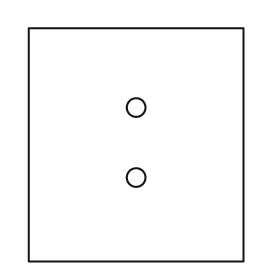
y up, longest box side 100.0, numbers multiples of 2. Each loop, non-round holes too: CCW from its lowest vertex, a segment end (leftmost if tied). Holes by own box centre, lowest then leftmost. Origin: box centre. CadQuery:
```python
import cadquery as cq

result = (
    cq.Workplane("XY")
    .moveTo(-46.0, -50.0)
    .lineTo(46.0, -50.0)
    .lineTo(46.0, 50.0)
    .lineTo(-46.0, 50.0)
    .close()
    .moveTo(0.0, -14.0)
    .circle(4.0)
    .moveTo(0.0, 16.0)
    .circle(4.0)
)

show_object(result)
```